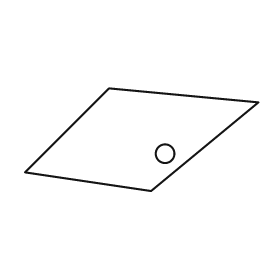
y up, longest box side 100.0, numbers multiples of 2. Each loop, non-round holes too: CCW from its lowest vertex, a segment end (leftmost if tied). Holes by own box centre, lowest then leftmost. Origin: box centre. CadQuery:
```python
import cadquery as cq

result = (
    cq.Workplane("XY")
    .moveTo(4.0, -22.0)
    .lineTo(50.0, 16.0)
    .lineTo(-14.0, 22.0)
    .lineTo(-50.0, -14.0)
    .close()
    .moveTo(10.0, -6.0)
    .circle(4.0)
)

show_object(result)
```